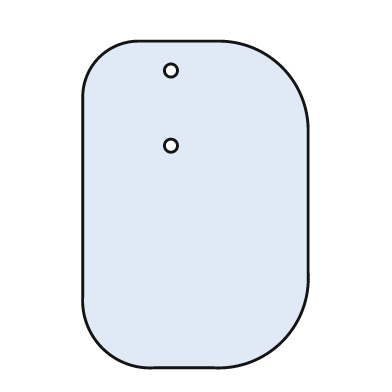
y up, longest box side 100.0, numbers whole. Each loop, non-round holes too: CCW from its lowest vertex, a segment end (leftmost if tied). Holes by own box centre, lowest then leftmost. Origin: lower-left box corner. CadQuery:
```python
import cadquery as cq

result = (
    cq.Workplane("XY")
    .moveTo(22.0, 0.0)
    .lineTo(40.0, 0.0)
    .threePointArc((61.0, 8.0), (69.0, 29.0))
    .lineTo(69.0, 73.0)
    .threePointArc((61.0, 92.0), (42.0, 100.0))
    .lineTo(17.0, 100.0)
    .threePointArc((5.0, 95.0), (0.0, 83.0))
    .lineTo(0.0, 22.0)
    .threePointArc((6.0, 6.0), (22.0, 0.0))
    .close()
    .moveTo(27.0, 68.0)
    .circle(2.0)
    .moveTo(27.0, 91.0)
    .circle(2.0)
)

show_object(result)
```